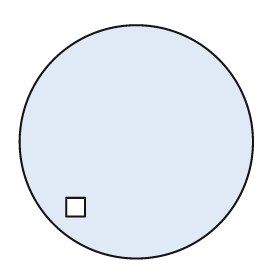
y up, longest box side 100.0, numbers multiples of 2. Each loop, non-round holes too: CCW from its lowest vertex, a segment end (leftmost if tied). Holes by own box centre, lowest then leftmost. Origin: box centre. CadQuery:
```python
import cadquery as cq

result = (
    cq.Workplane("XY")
    .moveTo(0.0, 0.0)
    .circle(50.0)
    .moveTo(-30.0, -32.0)
    .lineTo(-22.0, -32.0)
    .lineTo(-22.0, -24.0)
    .lineTo(-30.0, -24.0)
    .close()
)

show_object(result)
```